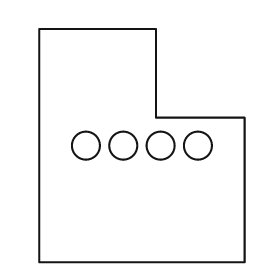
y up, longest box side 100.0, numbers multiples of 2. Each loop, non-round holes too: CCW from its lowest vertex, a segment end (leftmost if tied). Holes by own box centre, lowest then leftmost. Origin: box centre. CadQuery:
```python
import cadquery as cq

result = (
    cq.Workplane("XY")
    .moveTo(-44.0, -50.0)
    .lineTo(44.0, -50.0)
    .lineTo(44.0, 12.0)
    .lineTo(6.0, 12.0)
    .lineTo(6.0, 50.0)
    .lineTo(-44.0, 50.0)
    .close()
    .moveTo(-24.0, 0.0)
    .circle(6.0)
    .moveTo(-8.0, 0.0)
    .circle(6.0)
    .moveTo(8.0, 0.0)
    .circle(6.0)
    .moveTo(24.0, 0.0)
    .circle(6.0)
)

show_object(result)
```